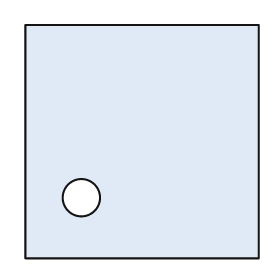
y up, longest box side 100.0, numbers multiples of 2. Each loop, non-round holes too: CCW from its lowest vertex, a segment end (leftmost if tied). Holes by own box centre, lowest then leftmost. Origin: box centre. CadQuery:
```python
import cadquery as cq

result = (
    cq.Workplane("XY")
    .moveTo(-50.0, -50.0)
    .lineTo(50.0, -50.0)
    .lineTo(50.0, 50.0)
    .lineTo(-50.0, 50.0)
    .close()
    .moveTo(-26.0, -24.0)
    .circle(8.0)
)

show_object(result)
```